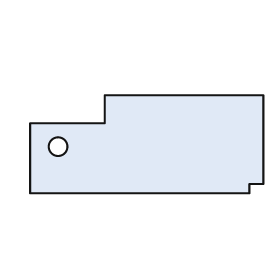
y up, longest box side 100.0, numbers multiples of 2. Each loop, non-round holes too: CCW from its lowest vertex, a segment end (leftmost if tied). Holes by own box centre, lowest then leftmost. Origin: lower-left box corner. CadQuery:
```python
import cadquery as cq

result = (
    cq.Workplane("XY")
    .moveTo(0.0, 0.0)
    .lineTo(94.0, 0.0)
    .lineTo(94.0, 4.0)
    .lineTo(100.0, 4.0)
    .lineTo(100.0, 42.0)
    .lineTo(32.0, 42.0)
    .lineTo(32.0, 30.0)
    .lineTo(0.0, 30.0)
    .close()
    .moveTo(12.0, 20.0)
    .circle(4.0)
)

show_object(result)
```